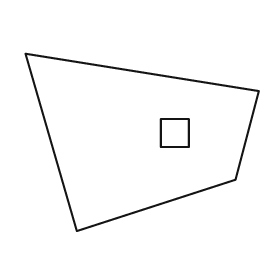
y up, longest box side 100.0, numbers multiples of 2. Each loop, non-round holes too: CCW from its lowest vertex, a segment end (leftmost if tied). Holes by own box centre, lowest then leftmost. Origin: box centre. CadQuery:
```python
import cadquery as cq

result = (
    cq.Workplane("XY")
    .moveTo(-28.0, -38.0)
    .lineTo(40.0, -16.0)
    .lineTo(50.0, 22.0)
    .lineTo(-50.0, 38.0)
    .close()
    .moveTo(8.0, -2.0)
    .lineTo(20.0, -2.0)
    .lineTo(20.0, 10.0)
    .lineTo(8.0, 10.0)
    .close()
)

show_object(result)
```